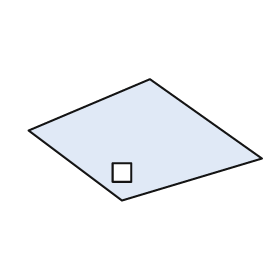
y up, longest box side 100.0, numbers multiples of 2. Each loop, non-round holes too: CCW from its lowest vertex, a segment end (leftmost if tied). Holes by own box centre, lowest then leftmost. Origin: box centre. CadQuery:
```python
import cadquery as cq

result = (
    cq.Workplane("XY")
    .moveTo(-10.0, -26.0)
    .lineTo(50.0, -8.0)
    .lineTo(2.0, 26.0)
    .lineTo(-50.0, 4.0)
    .close()
    .moveTo(-14.0, -18.0)
    .lineTo(-6.0, -18.0)
    .lineTo(-6.0, -10.0)
    .lineTo(-14.0, -10.0)
    .close()
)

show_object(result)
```